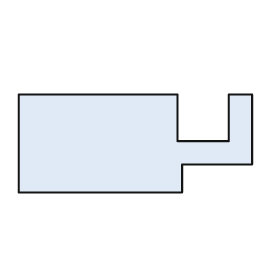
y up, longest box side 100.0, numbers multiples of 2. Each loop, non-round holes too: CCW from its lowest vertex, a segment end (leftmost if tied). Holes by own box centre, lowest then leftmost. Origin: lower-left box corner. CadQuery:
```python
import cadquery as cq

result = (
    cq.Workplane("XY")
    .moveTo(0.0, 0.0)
    .lineTo(70.0, 0.0)
    .lineTo(70.0, 12.0)
    .lineTo(100.0, 12.0)
    .lineTo(100.0, 42.0)
    .lineTo(90.0, 42.0)
    .lineTo(90.0, 22.0)
    .lineTo(68.0, 22.0)
    .lineTo(68.0, 42.0)
    .lineTo(0.0, 42.0)
    .close()
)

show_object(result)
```